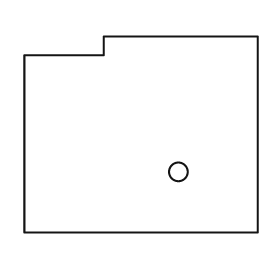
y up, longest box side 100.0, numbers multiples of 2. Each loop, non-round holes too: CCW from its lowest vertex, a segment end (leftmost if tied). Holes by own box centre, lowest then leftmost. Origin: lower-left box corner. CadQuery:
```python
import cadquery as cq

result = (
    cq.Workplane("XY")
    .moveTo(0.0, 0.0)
    .lineTo(100.0, 0.0)
    .lineTo(100.0, 84.0)
    .lineTo(34.0, 84.0)
    .lineTo(34.0, 76.0)
    .lineTo(0.0, 76.0)
    .close()
    .moveTo(66.0, 26.0)
    .circle(4.0)
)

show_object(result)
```